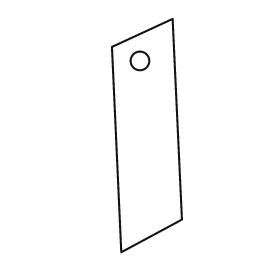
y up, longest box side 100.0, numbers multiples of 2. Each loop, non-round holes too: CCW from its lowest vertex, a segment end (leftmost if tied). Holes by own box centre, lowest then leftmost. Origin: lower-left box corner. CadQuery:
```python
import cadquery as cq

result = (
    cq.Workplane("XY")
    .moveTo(4.0, 0.0)
    .lineTo(30.0, 14.0)
    .lineTo(26.0, 100.0)
    .lineTo(0.0, 88.0)
    .close()
    .moveTo(12.0, 82.0)
    .circle(4.0)
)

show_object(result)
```